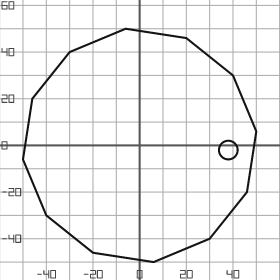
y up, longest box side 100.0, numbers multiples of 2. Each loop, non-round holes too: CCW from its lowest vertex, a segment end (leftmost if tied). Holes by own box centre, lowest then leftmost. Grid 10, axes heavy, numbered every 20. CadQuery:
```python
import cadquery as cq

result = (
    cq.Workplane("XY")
    .moveTo(6.0, -50.0)
    .lineTo(30.0, -40.0)
    .lineTo(46.0, -20.0)
    .lineTo(50.0, 6.0)
    .lineTo(40.0, 30.0)
    .lineTo(20.0, 46.0)
    .lineTo(-6.0, 50.0)
    .lineTo(-30.0, 40.0)
    .lineTo(-46.0, 20.0)
    .lineTo(-50.0, -6.0)
    .lineTo(-40.0, -30.0)
    .lineTo(-20.0, -46.0)
    .close()
    .moveTo(38.0, -2.0)
    .circle(4.0)
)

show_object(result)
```